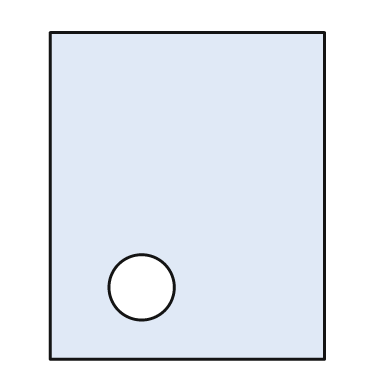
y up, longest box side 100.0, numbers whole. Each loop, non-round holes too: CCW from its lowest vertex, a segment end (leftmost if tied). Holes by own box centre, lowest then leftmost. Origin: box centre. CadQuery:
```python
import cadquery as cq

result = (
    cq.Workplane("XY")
    .moveTo(-42.0, -50.0)
    .lineTo(42.0, -50.0)
    .lineTo(42.0, 50.0)
    .lineTo(-42.0, 50.0)
    .close()
    .moveTo(-14.0, -28.0)
    .circle(10.0)
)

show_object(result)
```